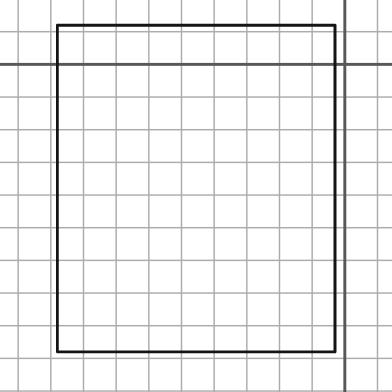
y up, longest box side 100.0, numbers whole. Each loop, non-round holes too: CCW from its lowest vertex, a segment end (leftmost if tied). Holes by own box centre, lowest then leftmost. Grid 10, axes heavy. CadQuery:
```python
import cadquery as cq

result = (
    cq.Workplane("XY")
    .moveTo(-88.0, -88.0)
    .lineTo(-3.0, -88.0)
    .lineTo(-3.0, 12.0)
    .lineTo(-88.0, 12.0)
    .close()
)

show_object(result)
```